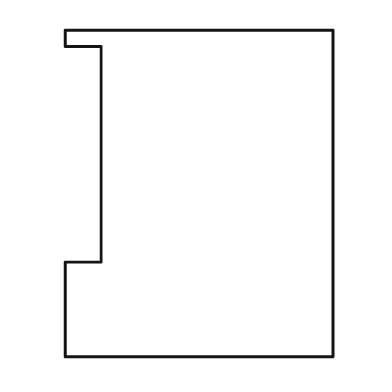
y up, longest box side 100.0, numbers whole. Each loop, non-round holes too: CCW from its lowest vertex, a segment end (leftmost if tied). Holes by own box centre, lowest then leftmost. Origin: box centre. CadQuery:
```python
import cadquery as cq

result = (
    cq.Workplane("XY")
    .moveTo(-41.0, -50.0)
    .lineTo(41.0, -50.0)
    .lineTo(41.0, 50.0)
    .lineTo(-41.0, 50.0)
    .lineTo(-41.0, 45.0)
    .lineTo(-30.0, 45.0)
    .lineTo(-30.0, -21.0)
    .lineTo(-41.0, -21.0)
    .close()
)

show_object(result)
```